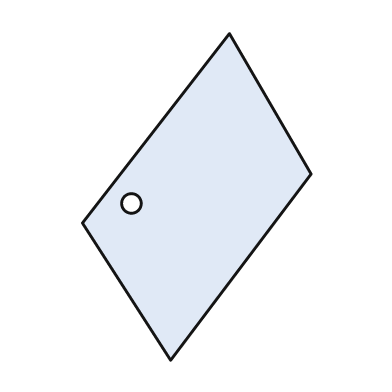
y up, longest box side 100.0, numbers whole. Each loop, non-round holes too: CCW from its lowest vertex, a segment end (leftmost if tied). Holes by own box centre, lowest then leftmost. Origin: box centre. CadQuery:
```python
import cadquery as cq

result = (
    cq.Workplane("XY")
    .moveTo(-8.0, -50.0)
    .lineTo(35.0, 7.0)
    .lineTo(10.0, 50.0)
    .lineTo(-35.0, -8.0)
    .close()
    .moveTo(-20.0, -2.0)
    .circle(3.0)
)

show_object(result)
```